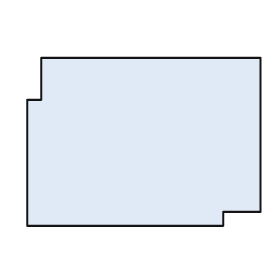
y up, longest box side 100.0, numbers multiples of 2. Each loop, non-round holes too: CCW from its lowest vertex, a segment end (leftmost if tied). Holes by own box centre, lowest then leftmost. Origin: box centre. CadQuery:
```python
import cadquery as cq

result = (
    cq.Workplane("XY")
    .moveTo(-50.0, -36.0)
    .lineTo(34.0, -36.0)
    .lineTo(34.0, -30.0)
    .lineTo(50.0, -30.0)
    .lineTo(50.0, 36.0)
    .lineTo(-44.0, 36.0)
    .lineTo(-44.0, 18.0)
    .lineTo(-50.0, 18.0)
    .close()
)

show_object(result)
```